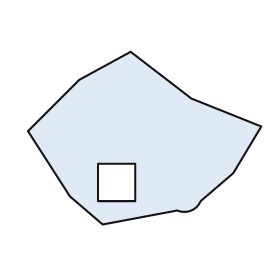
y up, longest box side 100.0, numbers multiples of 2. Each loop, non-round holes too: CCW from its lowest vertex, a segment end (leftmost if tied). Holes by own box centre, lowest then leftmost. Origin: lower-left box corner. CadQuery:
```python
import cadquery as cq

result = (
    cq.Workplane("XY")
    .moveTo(32.0, 0.0)
    .lineTo(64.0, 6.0)
    .threePointArc((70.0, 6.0), (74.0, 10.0))
    .lineTo(88.0, 22.0)
    .lineTo(100.0, 42.0)
    .lineTo(70.0, 54.0)
    .lineTo(44.0, 74.0)
    .lineTo(22.0, 62.0)
    .lineTo(0.0, 40.0)
    .lineTo(18.0, 12.0)
    .close()
    .moveTo(30.0, 10.0)
    .lineTo(46.0, 10.0)
    .lineTo(46.0, 26.0)
    .lineTo(30.0, 26.0)
    .close()
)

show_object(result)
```